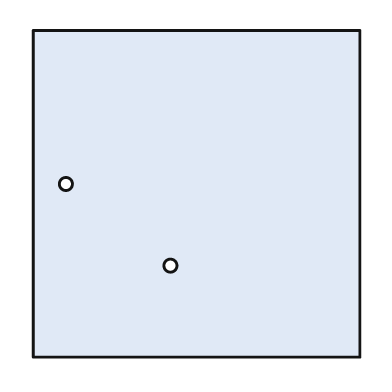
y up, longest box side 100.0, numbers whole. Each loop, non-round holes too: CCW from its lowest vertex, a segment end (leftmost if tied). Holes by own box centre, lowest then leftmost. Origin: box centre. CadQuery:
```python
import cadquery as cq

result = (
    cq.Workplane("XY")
    .moveTo(-50.0, -50.0)
    .lineTo(50.0, -50.0)
    .lineTo(50.0, 50.0)
    .lineTo(-50.0, 50.0)
    .close()
    .moveTo(-8.0, -22.0)
    .circle(2.0)
    .moveTo(-40.0, 3.0)
    .circle(2.0)
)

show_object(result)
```